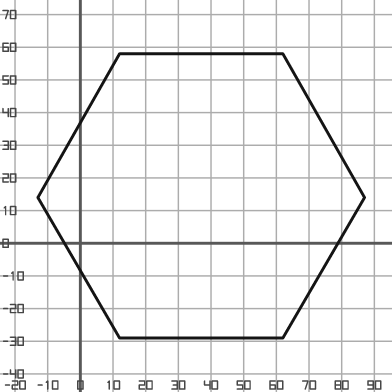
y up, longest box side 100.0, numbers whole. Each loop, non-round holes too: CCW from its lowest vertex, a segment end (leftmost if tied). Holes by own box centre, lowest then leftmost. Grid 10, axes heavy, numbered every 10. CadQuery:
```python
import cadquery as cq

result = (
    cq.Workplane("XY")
    .moveTo(12.0, -29.0)
    .lineTo(62.0, -29.0)
    .lineTo(87.0, 14.0)
    .lineTo(62.0, 58.0)
    .lineTo(12.0, 58.0)
    .lineTo(-13.0, 14.0)
    .close()
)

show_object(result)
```